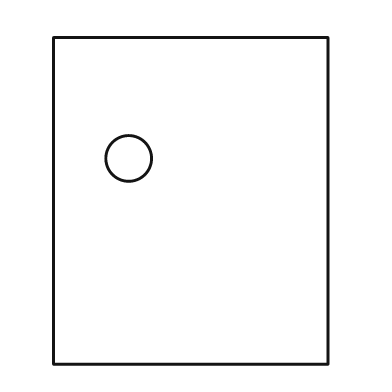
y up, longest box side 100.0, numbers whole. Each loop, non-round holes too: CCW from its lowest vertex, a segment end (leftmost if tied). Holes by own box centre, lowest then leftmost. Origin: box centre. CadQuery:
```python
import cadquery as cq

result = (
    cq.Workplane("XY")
    .moveTo(-42.0, -50.0)
    .lineTo(42.0, -50.0)
    .lineTo(42.0, 50.0)
    .lineTo(-42.0, 50.0)
    .close()
    .moveTo(-19.0, 13.0)
    .circle(7.0)
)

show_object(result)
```